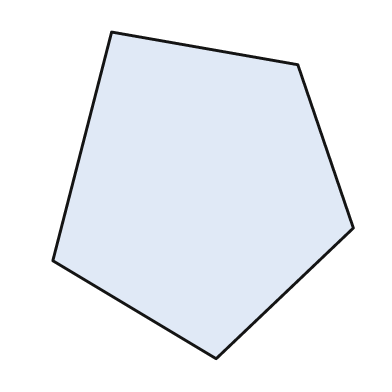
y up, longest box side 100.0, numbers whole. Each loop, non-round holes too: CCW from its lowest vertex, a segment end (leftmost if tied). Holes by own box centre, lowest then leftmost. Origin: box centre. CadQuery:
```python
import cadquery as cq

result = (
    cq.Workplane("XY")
    .moveTo(4.0, -50.0)
    .lineTo(46.0, -10.0)
    .lineTo(29.0, 40.0)
    .lineTo(-28.0, 50.0)
    .lineTo(-46.0, -20.0)
    .close()
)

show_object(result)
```